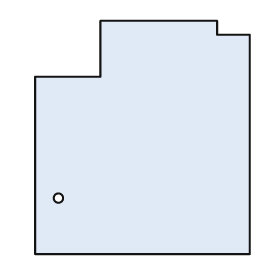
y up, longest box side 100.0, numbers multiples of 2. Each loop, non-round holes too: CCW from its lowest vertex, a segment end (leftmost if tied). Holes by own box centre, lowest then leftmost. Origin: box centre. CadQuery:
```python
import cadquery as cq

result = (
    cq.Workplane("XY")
    .moveTo(-46.0, -50.0)
    .lineTo(46.0, -50.0)
    .lineTo(46.0, 44.0)
    .lineTo(32.0, 44.0)
    .lineTo(32.0, 50.0)
    .lineTo(-18.0, 50.0)
    .lineTo(-18.0, 26.0)
    .lineTo(-46.0, 26.0)
    .close()
    .moveTo(-36.0, -26.0)
    .circle(2.0)
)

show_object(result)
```